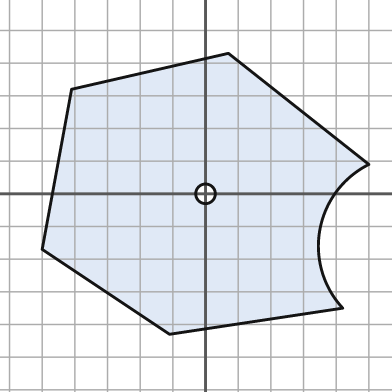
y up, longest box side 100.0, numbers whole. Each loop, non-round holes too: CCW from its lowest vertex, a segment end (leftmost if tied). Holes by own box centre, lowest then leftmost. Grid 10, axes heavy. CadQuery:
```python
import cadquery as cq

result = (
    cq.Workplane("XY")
    .moveTo(-11.0, -43.0)
    .lineTo(42.0, -35.0)
    .threePointArc((35.0, -11.0), (50.0, 9.0))
    .lineTo(7.0, 43.0)
    .lineTo(-41.0, 32.0)
    .lineTo(-50.0, -17.0)
    .close()
    .moveTo(0.0, 0.0)
    .circle(3.0)
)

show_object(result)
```